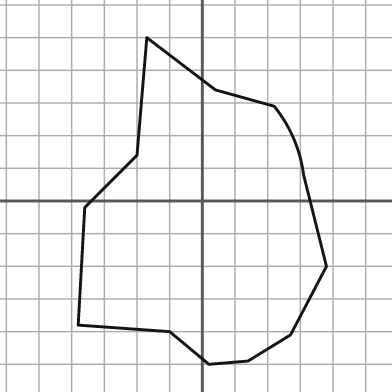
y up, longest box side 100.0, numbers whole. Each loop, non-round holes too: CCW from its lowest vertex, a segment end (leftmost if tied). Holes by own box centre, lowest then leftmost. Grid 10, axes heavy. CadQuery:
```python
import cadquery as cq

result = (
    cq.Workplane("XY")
    .moveTo(2.0, -50.0)
    .lineTo(14.0, -49.0)
    .lineTo(27.0, -41.0)
    .lineTo(38.0, -20.0)
    .lineTo(31.0, 8.0)
    .threePointArc((28.0, 19.0), (22.0, 29.0))
    .lineTo(4.0, 34.0)
    .lineTo(-17.0, 50.0)
    .lineTo(-20.0, 14.0)
    .lineTo(-36.0, -2.0)
    .lineTo(-38.0, -38.0)
    .lineTo(-10.0, -40.0)
    .close()
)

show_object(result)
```